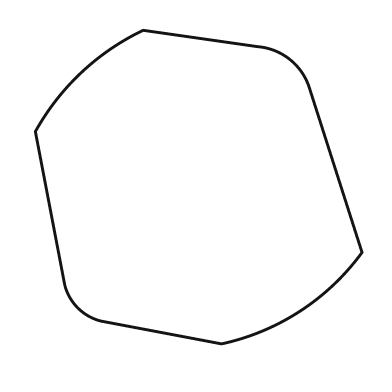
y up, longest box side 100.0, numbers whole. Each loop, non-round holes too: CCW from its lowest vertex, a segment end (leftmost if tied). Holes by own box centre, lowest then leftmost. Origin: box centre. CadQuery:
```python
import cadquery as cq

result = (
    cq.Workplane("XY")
    .moveTo(7.0, -48.0)
    .threePointArc((31.0, -38.0), (50.0, -20.0))
    .lineTo(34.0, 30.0)
    .threePointArc((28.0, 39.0), (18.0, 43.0))
    .lineTo(-17.0, 48.0)
    .threePointArc((-36.0, 35.0), (-50.0, 17.0))
    .lineTo(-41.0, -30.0)
    .threePointArc((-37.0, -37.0), (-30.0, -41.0))
    .close()
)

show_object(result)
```